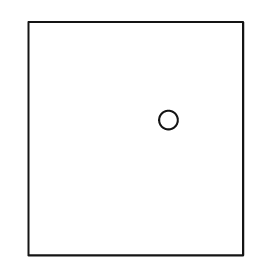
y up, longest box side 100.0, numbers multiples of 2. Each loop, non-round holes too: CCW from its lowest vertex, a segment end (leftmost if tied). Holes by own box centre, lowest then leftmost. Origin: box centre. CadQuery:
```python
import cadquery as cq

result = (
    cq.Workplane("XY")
    .moveTo(-46.0, -50.0)
    .lineTo(46.0, -50.0)
    .lineTo(46.0, 50.0)
    .lineTo(-46.0, 50.0)
    .close()
    .moveTo(14.0, 8.0)
    .circle(4.0)
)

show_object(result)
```